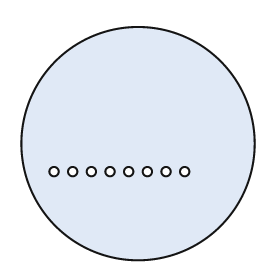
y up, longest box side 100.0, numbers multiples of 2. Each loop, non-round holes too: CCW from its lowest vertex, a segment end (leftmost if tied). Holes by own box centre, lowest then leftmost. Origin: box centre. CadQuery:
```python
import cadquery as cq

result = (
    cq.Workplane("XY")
    .moveTo(0.0, 0.0)
    .circle(50.0)
    .moveTo(-36.0, -12.0)
    .circle(2.0)
    .moveTo(-28.0, -12.0)
    .circle(2.0)
    .moveTo(-20.0, -12.0)
    .circle(2.0)
    .moveTo(-12.0, -12.0)
    .circle(2.0)
    .moveTo(-4.0, -12.0)
    .circle(2.0)
    .moveTo(4.0, -12.0)
    .circle(2.0)
    .moveTo(12.0, -12.0)
    .circle(2.0)
    .moveTo(20.0, -12.0)
    .circle(2.0)
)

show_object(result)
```